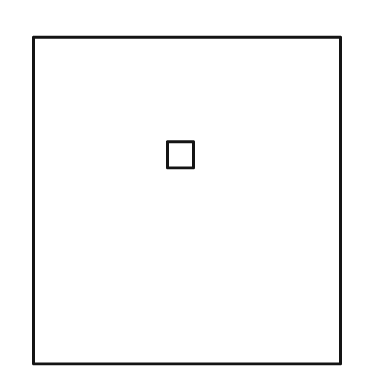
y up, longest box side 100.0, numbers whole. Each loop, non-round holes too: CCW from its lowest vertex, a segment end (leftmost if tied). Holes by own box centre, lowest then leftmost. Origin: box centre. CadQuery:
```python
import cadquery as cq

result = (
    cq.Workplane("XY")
    .moveTo(-47.0, -50.0)
    .lineTo(47.0, -50.0)
    .lineTo(47.0, 50.0)
    .lineTo(-47.0, 50.0)
    .close()
    .moveTo(-6.0, 10.0)
    .lineTo(2.0, 10.0)
    .lineTo(2.0, 18.0)
    .lineTo(-6.0, 18.0)
    .close()
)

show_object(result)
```